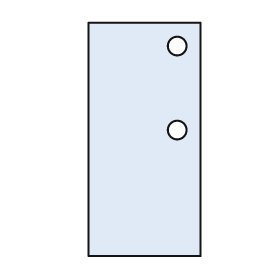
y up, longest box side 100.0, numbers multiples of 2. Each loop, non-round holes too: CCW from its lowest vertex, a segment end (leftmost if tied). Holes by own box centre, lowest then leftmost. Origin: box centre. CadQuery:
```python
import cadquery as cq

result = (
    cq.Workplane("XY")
    .moveTo(-24.0, -50.0)
    .lineTo(24.0, -50.0)
    .lineTo(24.0, 50.0)
    .lineTo(-24.0, 50.0)
    .close()
    .moveTo(14.0, 4.0)
    .circle(4.0)
    .moveTo(14.0, 40.0)
    .circle(4.0)
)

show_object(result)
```